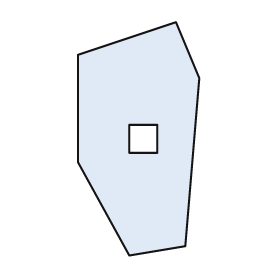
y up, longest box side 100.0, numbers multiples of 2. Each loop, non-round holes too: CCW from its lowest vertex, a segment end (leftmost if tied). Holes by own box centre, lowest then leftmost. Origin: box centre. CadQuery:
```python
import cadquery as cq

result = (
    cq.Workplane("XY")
    .moveTo(-4.0, -50.0)
    .lineTo(20.0, -46.0)
    .lineTo(26.0, 26.0)
    .lineTo(16.0, 50.0)
    .lineTo(-26.0, 36.0)
    .lineTo(-26.0, -10.0)
    .close()
    .moveTo(-4.0, -6.0)
    .lineTo(8.0, -6.0)
    .lineTo(8.0, 6.0)
    .lineTo(-4.0, 6.0)
    .close()
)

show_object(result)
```